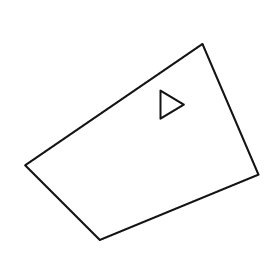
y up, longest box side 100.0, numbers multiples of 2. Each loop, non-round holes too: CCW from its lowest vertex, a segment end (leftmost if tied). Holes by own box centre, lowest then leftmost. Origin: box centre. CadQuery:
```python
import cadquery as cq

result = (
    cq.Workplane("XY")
    .moveTo(-18.0, -42.0)
    .lineTo(50.0, -14.0)
    .lineTo(26.0, 42.0)
    .lineTo(-50.0, -10.0)
    .close()
    .moveTo(8.0, 10.0)
    .lineTo(18.0, 16.0)
    .lineTo(8.0, 22.0)
    .close()
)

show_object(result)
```